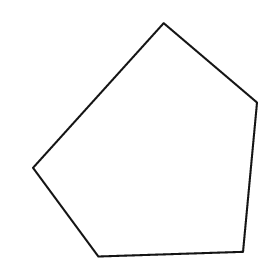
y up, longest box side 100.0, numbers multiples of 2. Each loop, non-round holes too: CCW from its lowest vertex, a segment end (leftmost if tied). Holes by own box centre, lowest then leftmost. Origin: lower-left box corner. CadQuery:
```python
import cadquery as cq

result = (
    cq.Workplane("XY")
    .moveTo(28.0, 0.0)
    .lineTo(90.0, 2.0)
    .lineTo(96.0, 66.0)
    .lineTo(56.0, 100.0)
    .lineTo(0.0, 38.0)
    .close()
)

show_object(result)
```